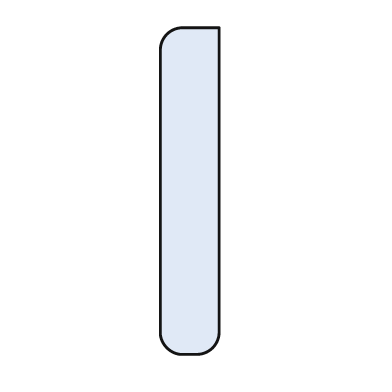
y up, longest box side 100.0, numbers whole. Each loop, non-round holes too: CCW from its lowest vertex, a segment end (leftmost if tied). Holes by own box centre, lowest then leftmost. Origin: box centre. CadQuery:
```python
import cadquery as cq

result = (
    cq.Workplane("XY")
    .moveTo(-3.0, -50.0)
    .lineTo(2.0, -50.0)
    .threePointArc((7.0, -48.0), (9.0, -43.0))
    .lineTo(9.0, 50.0)
    .lineTo(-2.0, 50.0)
    .threePointArc((-7.0, 48.0), (-9.0, 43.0))
    .lineTo(-9.0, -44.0)
    .threePointArc((-7.0, -48.0), (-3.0, -50.0))
    .close()
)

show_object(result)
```